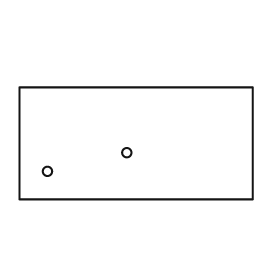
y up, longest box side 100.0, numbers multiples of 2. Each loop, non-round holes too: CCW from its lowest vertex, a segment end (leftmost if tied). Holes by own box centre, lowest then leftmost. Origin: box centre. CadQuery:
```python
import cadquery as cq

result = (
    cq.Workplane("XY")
    .moveTo(-50.0, -24.0)
    .lineTo(50.0, -24.0)
    .lineTo(50.0, 24.0)
    .lineTo(-50.0, 24.0)
    .close()
    .moveTo(-38.0, -12.0)
    .circle(2.0)
    .moveTo(-4.0, -4.0)
    .circle(2.0)
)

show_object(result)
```